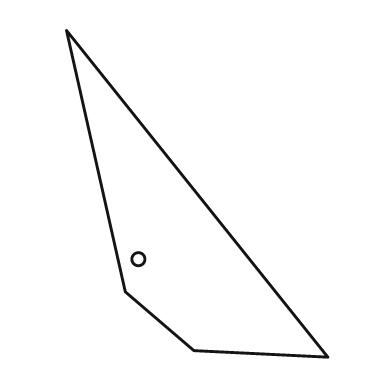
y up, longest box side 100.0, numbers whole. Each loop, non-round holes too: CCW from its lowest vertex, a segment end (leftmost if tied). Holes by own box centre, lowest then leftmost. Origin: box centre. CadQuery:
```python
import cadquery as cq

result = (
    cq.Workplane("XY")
    .moveTo(40.0, -50.0)
    .lineTo(-40.0, 50.0)
    .lineTo(-22.0, -30.0)
    .lineTo(-1.0, -48.0)
    .close()
    .moveTo(-18.0, -20.0)
    .circle(2.0)
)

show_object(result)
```